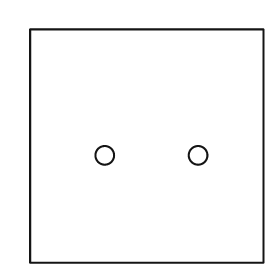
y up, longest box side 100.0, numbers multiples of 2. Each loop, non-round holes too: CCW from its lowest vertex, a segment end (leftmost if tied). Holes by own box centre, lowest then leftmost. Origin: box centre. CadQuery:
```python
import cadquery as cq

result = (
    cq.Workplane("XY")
    .moveTo(-50.0, -50.0)
    .lineTo(50.0, -50.0)
    .lineTo(50.0, 50.0)
    .lineTo(-50.0, 50.0)
    .close()
    .moveTo(-18.0, -4.0)
    .circle(4.0)
    .moveTo(22.0, -4.0)
    .circle(4.0)
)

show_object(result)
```